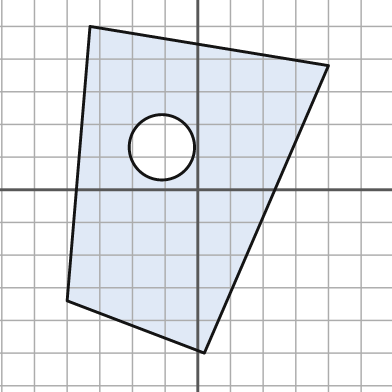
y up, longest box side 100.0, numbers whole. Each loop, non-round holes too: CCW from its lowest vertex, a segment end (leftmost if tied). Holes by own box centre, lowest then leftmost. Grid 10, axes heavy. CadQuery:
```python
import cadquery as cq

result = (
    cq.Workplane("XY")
    .moveTo(2.0, -50.0)
    .lineTo(40.0, 38.0)
    .lineTo(-33.0, 50.0)
    .lineTo(-40.0, -34.0)
    .close()
    .moveTo(-11.0, 13.0)
    .circle(10.0)
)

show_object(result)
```